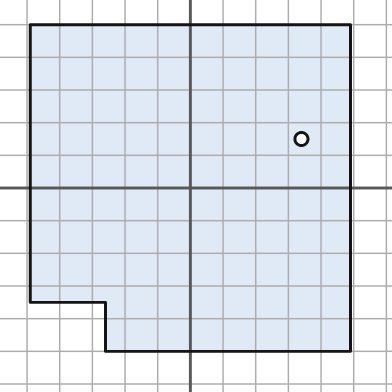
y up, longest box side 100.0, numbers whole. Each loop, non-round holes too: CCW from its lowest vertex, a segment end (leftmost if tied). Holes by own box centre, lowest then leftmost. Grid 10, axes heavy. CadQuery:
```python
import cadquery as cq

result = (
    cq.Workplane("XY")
    .moveTo(-26.0, -50.0)
    .lineTo(49.0, -50.0)
    .lineTo(49.0, 50.0)
    .lineTo(-49.0, 50.0)
    .lineTo(-49.0, -35.0)
    .lineTo(-26.0, -35.0)
    .close()
    .moveTo(34.0, 15.0)
    .circle(2.0)
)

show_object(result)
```